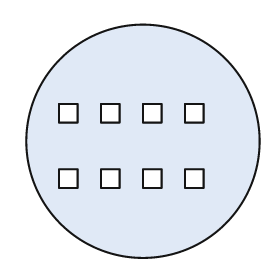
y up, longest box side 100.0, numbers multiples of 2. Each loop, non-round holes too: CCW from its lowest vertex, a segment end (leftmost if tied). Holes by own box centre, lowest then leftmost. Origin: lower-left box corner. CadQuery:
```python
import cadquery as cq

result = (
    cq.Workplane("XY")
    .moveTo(50.0, 50.0)
    .circle(50.0)
    .moveTo(14.0, 30.0)
    .lineTo(22.0, 30.0)
    .lineTo(22.0, 38.0)
    .lineTo(14.0, 38.0)
    .close()
    .moveTo(32.0, 30.0)
    .lineTo(40.0, 30.0)
    .lineTo(40.0, 38.0)
    .lineTo(32.0, 38.0)
    .close()
    .moveTo(50.0, 30.0)
    .lineTo(58.0, 30.0)
    .lineTo(58.0, 38.0)
    .lineTo(50.0, 38.0)
    .close()
    .moveTo(68.0, 30.0)
    .lineTo(76.0, 30.0)
    .lineTo(76.0, 38.0)
    .lineTo(68.0, 38.0)
    .close()
    .moveTo(14.0, 58.0)
    .lineTo(22.0, 58.0)
    .lineTo(22.0, 66.0)
    .lineTo(14.0, 66.0)
    .close()
    .moveTo(32.0, 58.0)
    .lineTo(40.0, 58.0)
    .lineTo(40.0, 66.0)
    .lineTo(32.0, 66.0)
    .close()
    .moveTo(50.0, 58.0)
    .lineTo(58.0, 58.0)
    .lineTo(58.0, 66.0)
    .lineTo(50.0, 66.0)
    .close()
    .moveTo(68.0, 58.0)
    .lineTo(76.0, 58.0)
    .lineTo(76.0, 66.0)
    .lineTo(68.0, 66.0)
    .close()
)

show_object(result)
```